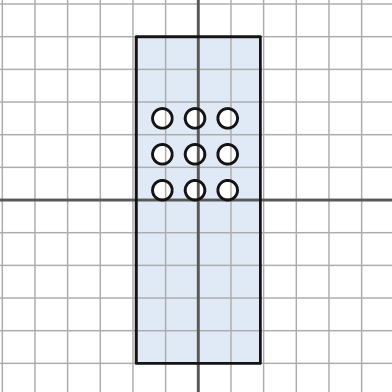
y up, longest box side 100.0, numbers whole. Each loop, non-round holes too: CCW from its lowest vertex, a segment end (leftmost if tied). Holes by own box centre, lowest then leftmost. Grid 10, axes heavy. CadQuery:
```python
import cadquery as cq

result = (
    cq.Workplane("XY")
    .moveTo(-19.0, -50.0)
    .lineTo(19.0, -50.0)
    .lineTo(19.0, 50.0)
    .lineTo(-19.0, 50.0)
    .close()
    .moveTo(-11.0, 3.0)
    .circle(3.0)
    .moveTo(-1.0, 3.0)
    .circle(3.0)
    .moveTo(9.0, 3.0)
    .circle(3.0)
    .moveTo(-11.0, 14.0)
    .circle(3.0)
    .moveTo(-1.0, 14.0)
    .circle(3.0)
    .moveTo(9.0, 14.0)
    .circle(3.0)
    .moveTo(-11.0, 25.0)
    .circle(3.0)
    .moveTo(-1.0, 25.0)
    .circle(3.0)
    .moveTo(9.0, 25.0)
    .circle(3.0)
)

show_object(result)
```